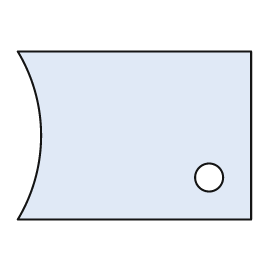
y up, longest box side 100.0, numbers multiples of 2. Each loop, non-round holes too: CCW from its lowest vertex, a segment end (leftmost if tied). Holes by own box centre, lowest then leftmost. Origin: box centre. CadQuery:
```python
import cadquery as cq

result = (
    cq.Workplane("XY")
    .moveTo(-50.0, -36.0)
    .lineTo(50.0, -36.0)
    .lineTo(50.0, 36.0)
    .lineTo(-50.0, 36.0)
    .threePointArc((-40.0, 0.0), (-50.0, -36.0))
    .close()
    .moveTo(32.0, -18.0)
    .circle(6.0)
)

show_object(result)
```